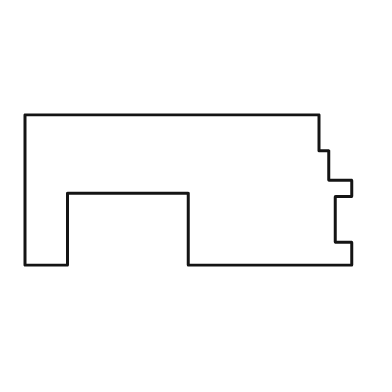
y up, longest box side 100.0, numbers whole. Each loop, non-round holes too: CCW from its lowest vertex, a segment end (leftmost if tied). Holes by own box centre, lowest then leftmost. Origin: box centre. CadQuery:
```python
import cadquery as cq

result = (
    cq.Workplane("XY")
    .moveTo(-50.0, -23.0)
    .lineTo(-37.0, -23.0)
    .lineTo(-37.0, -1.0)
    .lineTo(0.0, -1.0)
    .lineTo(0.0, -23.0)
    .lineTo(50.0, -23.0)
    .lineTo(50.0, -16.0)
    .lineTo(45.0, -16.0)
    .lineTo(45.0, -2.0)
    .lineTo(50.0, -2.0)
    .lineTo(50.0, 3.0)
    .lineTo(43.0, 3.0)
    .lineTo(43.0, 12.0)
    .lineTo(40.0, 12.0)
    .lineTo(40.0, 23.0)
    .lineTo(-50.0, 23.0)
    .close()
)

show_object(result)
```